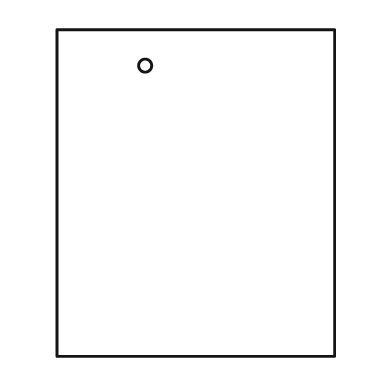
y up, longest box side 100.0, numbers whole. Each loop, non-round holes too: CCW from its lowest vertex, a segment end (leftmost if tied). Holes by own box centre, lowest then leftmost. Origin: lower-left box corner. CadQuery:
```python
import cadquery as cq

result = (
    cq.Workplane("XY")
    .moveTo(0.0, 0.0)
    .lineTo(85.0, 0.0)
    .lineTo(85.0, 100.0)
    .lineTo(0.0, 100.0)
    .close()
    .moveTo(27.0, 89.0)
    .circle(2.0)
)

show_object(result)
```